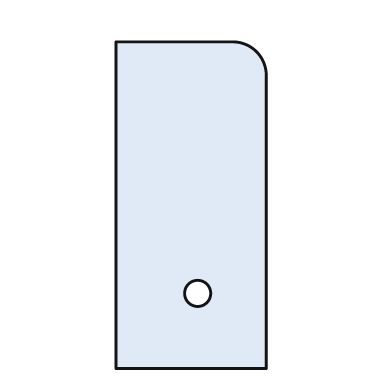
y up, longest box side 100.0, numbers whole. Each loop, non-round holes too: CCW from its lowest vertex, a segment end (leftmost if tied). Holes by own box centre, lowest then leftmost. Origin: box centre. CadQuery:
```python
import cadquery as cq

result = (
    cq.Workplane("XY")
    .moveTo(-23.0, -50.0)
    .lineTo(23.0, -50.0)
    .lineTo(23.0, 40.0)
    .threePointArc((20.0, 47.0), (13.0, 50.0))
    .lineTo(-23.0, 50.0)
    .close()
    .moveTo(2.0, -27.0)
    .circle(4.0)
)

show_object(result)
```